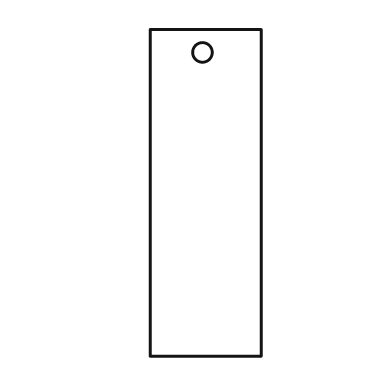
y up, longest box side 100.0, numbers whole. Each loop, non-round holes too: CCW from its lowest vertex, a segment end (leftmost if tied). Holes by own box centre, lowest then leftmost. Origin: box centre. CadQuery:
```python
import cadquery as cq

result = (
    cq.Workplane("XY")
    .moveTo(-17.0, -50.0)
    .lineTo(17.0, -50.0)
    .lineTo(17.0, 50.0)
    .lineTo(-17.0, 50.0)
    .close()
    .moveTo(-1.0, 43.0)
    .circle(3.0)
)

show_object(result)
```